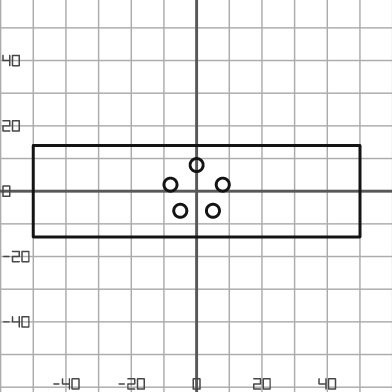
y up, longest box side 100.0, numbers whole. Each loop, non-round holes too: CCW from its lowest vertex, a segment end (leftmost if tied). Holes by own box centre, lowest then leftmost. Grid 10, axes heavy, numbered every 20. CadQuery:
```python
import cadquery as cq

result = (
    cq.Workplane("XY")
    .moveTo(-50.0, -14.0)
    .lineTo(50.0, -14.0)
    .lineTo(50.0, 14.0)
    .lineTo(-50.0, 14.0)
    .close()
    .moveTo(-5.0, -6.0)
    .circle(2.0)
    .moveTo(5.0, -6.0)
    .circle(2.0)
    .moveTo(-8.0, 2.0)
    .circle(2.0)
    .moveTo(8.0, 2.0)
    .circle(2.0)
    .moveTo(0.0, 8.0)
    .circle(2.0)
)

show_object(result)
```